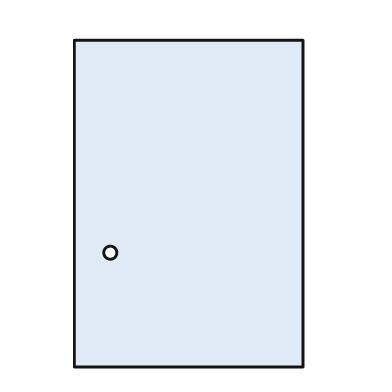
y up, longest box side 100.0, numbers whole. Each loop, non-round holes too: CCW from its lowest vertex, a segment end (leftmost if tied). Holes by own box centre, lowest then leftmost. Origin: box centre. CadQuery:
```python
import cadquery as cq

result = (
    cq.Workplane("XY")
    .moveTo(-35.0, -50.0)
    .lineTo(35.0, -50.0)
    .lineTo(35.0, 50.0)
    .lineTo(-35.0, 50.0)
    .close()
    .moveTo(-24.0, -15.0)
    .circle(2.0)
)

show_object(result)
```